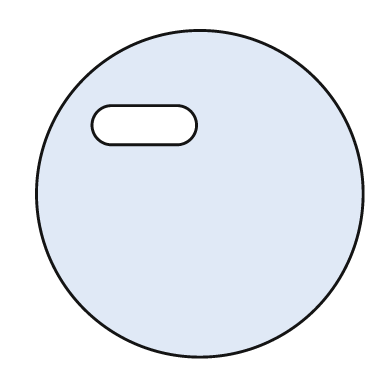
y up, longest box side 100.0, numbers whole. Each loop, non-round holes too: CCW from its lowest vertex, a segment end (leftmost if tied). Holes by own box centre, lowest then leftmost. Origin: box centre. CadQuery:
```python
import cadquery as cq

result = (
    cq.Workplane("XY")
    .moveTo(0.0, 0.0)
    .circle(50.0)
    .moveTo(-27.0, 15.0)
    .lineTo(-7.0, 15.0)
    .threePointArc((-1.0, 21.0), (-7.0, 27.0))
    .lineTo(-27.0, 27.0)
    .threePointArc((-33.0, 21.0), (-27.0, 15.0))
    .close()
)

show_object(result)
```